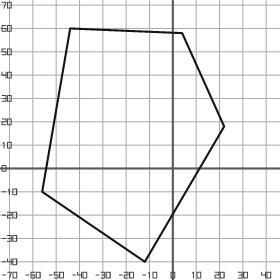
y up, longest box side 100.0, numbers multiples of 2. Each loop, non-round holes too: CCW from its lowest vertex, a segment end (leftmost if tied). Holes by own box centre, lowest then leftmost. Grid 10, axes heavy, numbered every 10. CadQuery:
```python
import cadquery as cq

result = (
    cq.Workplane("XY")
    .moveTo(-12.0, -40.0)
    .lineTo(22.0, 18.0)
    .lineTo(4.0, 58.0)
    .lineTo(-44.0, 60.0)
    .lineTo(-56.0, -10.0)
    .close()
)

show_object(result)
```